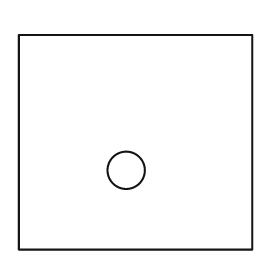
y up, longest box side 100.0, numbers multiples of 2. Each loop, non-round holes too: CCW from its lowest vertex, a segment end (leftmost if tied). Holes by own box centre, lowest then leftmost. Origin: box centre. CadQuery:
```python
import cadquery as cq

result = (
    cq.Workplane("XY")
    .moveTo(-50.0, -46.0)
    .lineTo(50.0, -46.0)
    .lineTo(50.0, 46.0)
    .lineTo(-50.0, 46.0)
    .close()
    .moveTo(-4.0, -12.0)
    .circle(8.0)
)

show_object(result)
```